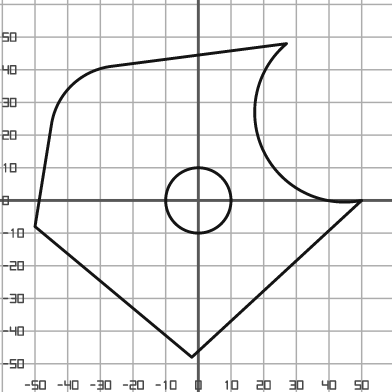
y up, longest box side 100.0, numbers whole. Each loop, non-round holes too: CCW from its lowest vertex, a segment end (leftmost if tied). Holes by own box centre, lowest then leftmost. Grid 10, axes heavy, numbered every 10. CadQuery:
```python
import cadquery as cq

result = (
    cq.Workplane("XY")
    .moveTo(-2.0, -48.0)
    .lineTo(50.0, 0.0)
    .threePointArc((20.0, 15.0), (27.0, 48.0))
    .lineTo(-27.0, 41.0)
    .threePointArc((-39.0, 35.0), (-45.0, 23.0))
    .lineTo(-50.0, -8.0)
    .close()
    .moveTo(0.0, 0.0)
    .circle(10.0)
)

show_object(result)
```